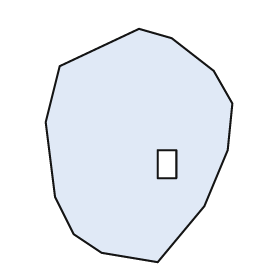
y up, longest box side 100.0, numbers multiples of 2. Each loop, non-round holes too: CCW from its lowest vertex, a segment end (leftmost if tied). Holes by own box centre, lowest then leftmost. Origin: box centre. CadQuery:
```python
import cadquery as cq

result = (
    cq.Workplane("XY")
    .moveTo(8.0, -50.0)
    .lineTo(28.0, -26.0)
    .lineTo(38.0, -2.0)
    .lineTo(40.0, 18.0)
    .lineTo(32.0, 32.0)
    .lineTo(14.0, 46.0)
    .lineTo(0.0, 50.0)
    .lineTo(-34.0, 34.0)
    .lineTo(-40.0, 10.0)
    .lineTo(-36.0, -22.0)
    .lineTo(-28.0, -38.0)
    .lineTo(-16.0, -46.0)
    .close()
    .moveTo(8.0, -14.0)
    .lineTo(16.0, -14.0)
    .lineTo(16.0, -2.0)
    .lineTo(8.0, -2.0)
    .close()
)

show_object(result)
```